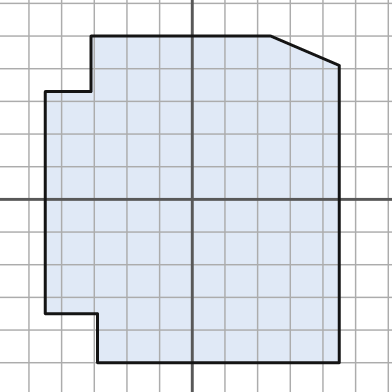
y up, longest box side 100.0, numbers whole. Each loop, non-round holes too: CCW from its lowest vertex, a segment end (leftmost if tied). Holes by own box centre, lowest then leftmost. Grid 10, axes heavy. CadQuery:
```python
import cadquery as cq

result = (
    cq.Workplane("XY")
    .moveTo(-29.0, -50.0)
    .lineTo(45.0, -50.0)
    .lineTo(45.0, 41.0)
    .lineTo(24.0, 50.0)
    .lineTo(-31.0, 50.0)
    .lineTo(-31.0, 33.0)
    .lineTo(-45.0, 33.0)
    .lineTo(-45.0, -35.0)
    .lineTo(-29.0, -35.0)
    .close()
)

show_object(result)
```